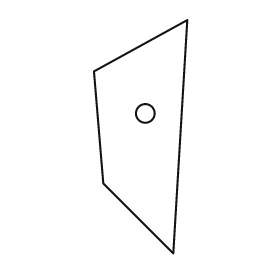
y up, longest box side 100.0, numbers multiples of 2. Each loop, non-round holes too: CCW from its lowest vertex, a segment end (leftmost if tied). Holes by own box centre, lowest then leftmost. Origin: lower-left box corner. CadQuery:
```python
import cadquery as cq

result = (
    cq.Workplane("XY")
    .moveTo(34.0, 0.0)
    .lineTo(40.0, 100.0)
    .lineTo(0.0, 78.0)
    .lineTo(4.0, 30.0)
    .close()
    .moveTo(22.0, 60.0)
    .circle(4.0)
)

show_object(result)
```